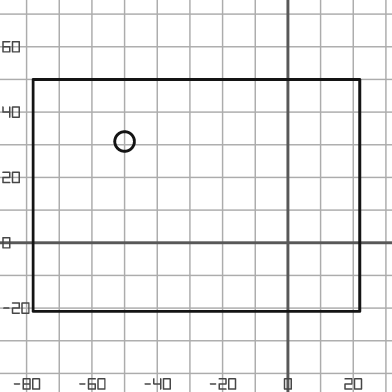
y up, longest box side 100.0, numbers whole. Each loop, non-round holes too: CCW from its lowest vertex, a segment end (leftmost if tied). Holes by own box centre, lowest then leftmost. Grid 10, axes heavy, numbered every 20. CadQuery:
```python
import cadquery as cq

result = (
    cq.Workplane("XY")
    .moveTo(-78.0, -21.0)
    .lineTo(22.0, -21.0)
    .lineTo(22.0, 50.0)
    .lineTo(-78.0, 50.0)
    .close()
    .moveTo(-50.0, 31.0)
    .circle(3.0)
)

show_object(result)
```